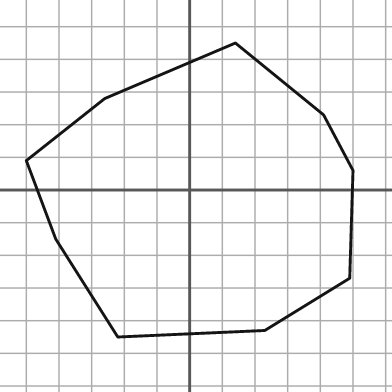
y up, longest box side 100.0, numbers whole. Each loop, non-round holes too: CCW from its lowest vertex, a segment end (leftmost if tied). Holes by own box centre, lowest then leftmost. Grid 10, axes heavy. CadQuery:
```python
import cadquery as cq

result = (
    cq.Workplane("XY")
    .moveTo(-22.0, -45.0)
    .lineTo(23.0, -43.0)
    .lineTo(49.0, -27.0)
    .lineTo(50.0, 6.0)
    .lineTo(41.0, 23.0)
    .lineTo(14.0, 45.0)
    .lineTo(-26.0, 28.0)
    .lineTo(-50.0, 9.0)
    .lineTo(-41.0, -15.0)
    .close()
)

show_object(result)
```